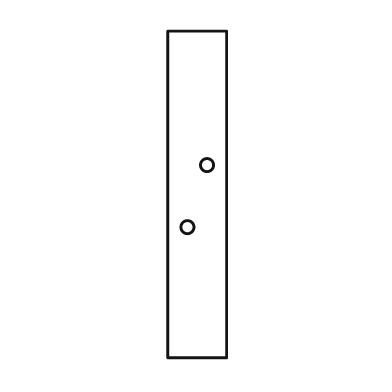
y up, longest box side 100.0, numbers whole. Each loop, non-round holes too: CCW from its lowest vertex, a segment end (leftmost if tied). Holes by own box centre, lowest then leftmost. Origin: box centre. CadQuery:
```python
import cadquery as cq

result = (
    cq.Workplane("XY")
    .moveTo(-9.0, -50.0)
    .lineTo(9.0, -50.0)
    .lineTo(9.0, 50.0)
    .lineTo(-9.0, 50.0)
    .close()
    .moveTo(-3.0, -10.0)
    .circle(2.0)
    .moveTo(3.0, 9.0)
    .circle(2.0)
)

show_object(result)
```